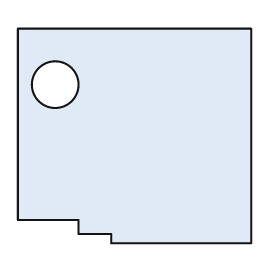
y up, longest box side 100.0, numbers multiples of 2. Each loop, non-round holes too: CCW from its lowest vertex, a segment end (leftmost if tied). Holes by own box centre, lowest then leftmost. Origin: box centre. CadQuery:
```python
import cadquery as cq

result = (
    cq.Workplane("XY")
    .moveTo(-10.0, -46.0)
    .lineTo(50.0, -46.0)
    .lineTo(50.0, 46.0)
    .lineTo(-50.0, 46.0)
    .lineTo(-50.0, -36.0)
    .lineTo(-24.0, -36.0)
    .lineTo(-24.0, -42.0)
    .lineTo(-10.0, -42.0)
    .close()
    .moveTo(-34.0, 22.0)
    .circle(10.0)
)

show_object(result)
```